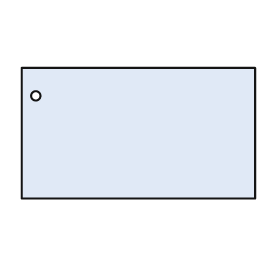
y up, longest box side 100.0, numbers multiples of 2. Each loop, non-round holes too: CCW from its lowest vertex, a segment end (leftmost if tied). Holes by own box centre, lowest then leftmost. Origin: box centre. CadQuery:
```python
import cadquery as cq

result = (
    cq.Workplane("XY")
    .moveTo(-50.0, -28.0)
    .lineTo(50.0, -28.0)
    .lineTo(50.0, 28.0)
    .lineTo(-50.0, 28.0)
    .close()
    .moveTo(-44.0, 16.0)
    .circle(2.0)
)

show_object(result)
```